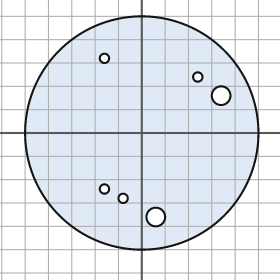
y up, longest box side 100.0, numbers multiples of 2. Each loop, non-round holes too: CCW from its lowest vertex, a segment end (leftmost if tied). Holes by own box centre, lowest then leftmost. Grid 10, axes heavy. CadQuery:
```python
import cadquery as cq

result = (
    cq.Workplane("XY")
    .moveTo(0.0, 0.0)
    .circle(50.0)
    .moveTo(6.0, -36.0)
    .circle(4.0)
    .moveTo(-8.0, -28.0)
    .circle(2.0)
    .moveTo(-16.0, -24.0)
    .circle(2.0)
    .moveTo(34.0, 16.0)
    .circle(4.0)
    .moveTo(24.0, 24.0)
    .circle(2.0)
    .moveTo(-16.0, 32.0)
    .circle(2.0)
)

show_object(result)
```